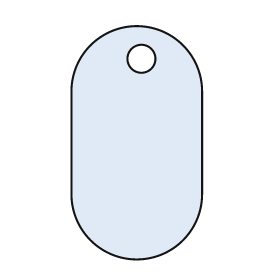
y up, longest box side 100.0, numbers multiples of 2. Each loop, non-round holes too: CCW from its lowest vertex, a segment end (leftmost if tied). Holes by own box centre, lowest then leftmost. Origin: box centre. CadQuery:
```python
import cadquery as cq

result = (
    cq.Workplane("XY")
    .moveTo(-28.0, -22.0)
    .threePointArc((0.0, -50.0), (28.0, -22.0))
    .lineTo(28.0, 22.0)
    .threePointArc((0.0, 50.0), (-28.0, 22.0))
    .close()
    .moveTo(2.0, 36.0)
    .circle(6.0)
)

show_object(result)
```